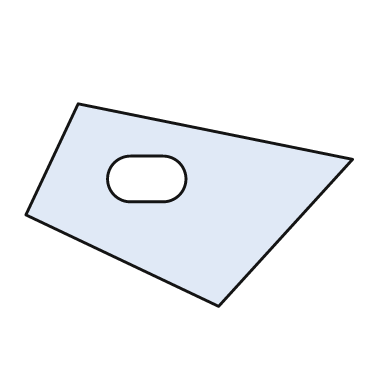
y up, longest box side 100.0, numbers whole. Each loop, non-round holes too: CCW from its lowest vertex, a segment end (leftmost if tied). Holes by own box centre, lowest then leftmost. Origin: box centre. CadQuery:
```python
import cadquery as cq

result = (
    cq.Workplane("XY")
    .moveTo(9.0, -31.0)
    .lineTo(50.0, 14.0)
    .lineTo(-34.0, 31.0)
    .lineTo(-50.0, -3.0)
    .close()
    .moveTo(-18.0, 1.0)
    .lineTo(-8.0, 1.0)
    .threePointArc((-1.0, 8.0), (-8.0, 15.0))
    .lineTo(-18.0, 15.0)
    .threePointArc((-25.0, 8.0), (-18.0, 1.0))
    .close()
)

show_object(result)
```